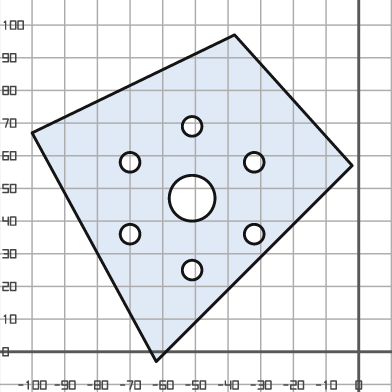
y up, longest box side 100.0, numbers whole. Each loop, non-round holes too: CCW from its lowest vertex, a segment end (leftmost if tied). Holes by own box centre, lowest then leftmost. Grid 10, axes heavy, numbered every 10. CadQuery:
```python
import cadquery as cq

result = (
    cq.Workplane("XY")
    .moveTo(-62.0, -3.0)
    .lineTo(-2.0, 57.0)
    .lineTo(-38.0, 97.0)
    .lineTo(-100.0, 67.0)
    .close()
    .moveTo(-51.0, 25.0)
    .circle(3.0)
    .moveTo(-70.0, 36.0)
    .circle(3.0)
    .moveTo(-32.0, 36.0)
    .circle(3.0)
    .moveTo(-51.0, 47.0)
    .circle(7.0)
    .moveTo(-70.0, 58.0)
    .circle(3.0)
    .moveTo(-32.0, 58.0)
    .circle(3.0)
    .moveTo(-51.0, 69.0)
    .circle(3.0)
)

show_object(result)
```